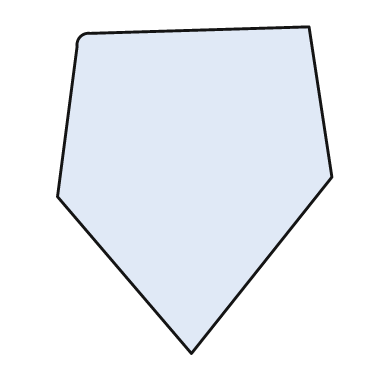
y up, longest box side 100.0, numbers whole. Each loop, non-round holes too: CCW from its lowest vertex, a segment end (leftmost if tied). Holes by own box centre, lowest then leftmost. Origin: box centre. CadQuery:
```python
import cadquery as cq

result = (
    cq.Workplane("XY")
    .moveTo(-1.0, -50.0)
    .lineTo(42.0, 4.0)
    .lineTo(35.0, 50.0)
    .lineTo(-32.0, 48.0)
    .threePointArc((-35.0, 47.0), (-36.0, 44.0))
    .lineTo(-42.0, -2.0)
    .close()
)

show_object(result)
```